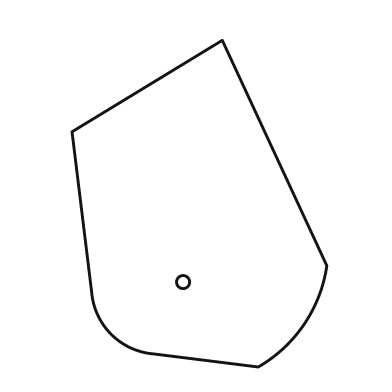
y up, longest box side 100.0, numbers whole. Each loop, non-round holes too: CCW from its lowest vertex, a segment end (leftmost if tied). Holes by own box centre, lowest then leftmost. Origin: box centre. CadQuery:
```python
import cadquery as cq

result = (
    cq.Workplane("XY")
    .moveTo(18.0, -50.0)
    .threePointArc((32.0, -37.0), (39.0, -19.0))
    .lineTo(7.0, 50.0)
    .lineTo(-39.0, 22.0)
    .lineTo(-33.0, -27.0)
    .threePointArc((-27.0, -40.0), (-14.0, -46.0))
    .close()
    .moveTo(-5.0, -24.0)
    .circle(2.0)
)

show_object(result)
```